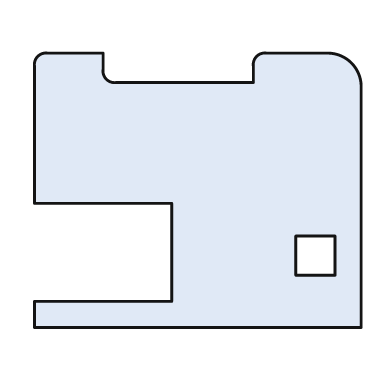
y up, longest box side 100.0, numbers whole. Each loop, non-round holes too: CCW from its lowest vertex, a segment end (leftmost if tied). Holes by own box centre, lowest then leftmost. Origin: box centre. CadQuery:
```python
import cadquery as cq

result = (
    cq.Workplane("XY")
    .moveTo(-50.0, -42.0)
    .lineTo(50.0, -42.0)
    .lineTo(50.0, 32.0)
    .threePointArc((47.0, 39.0), (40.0, 42.0))
    .lineTo(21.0, 42.0)
    .threePointArc((18.0, 41.0), (17.0, 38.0))
    .lineTo(17.0, 33.0)
    .lineTo(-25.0, 33.0)
    .threePointArc((-28.0, 34.0), (-29.0, 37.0))
    .lineTo(-29.0, 42.0)
    .lineTo(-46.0, 42.0)
    .threePointArc((-49.0, 41.0), (-50.0, 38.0))
    .lineTo(-50.0, -4.0)
    .lineTo(-8.0, -4.0)
    .lineTo(-8.0, -34.0)
    .lineTo(-50.0, -34.0)
    .close()
    .moveTo(30.0, -26.0)
    .lineTo(42.0, -26.0)
    .lineTo(42.0, -14.0)
    .lineTo(30.0, -14.0)
    .close()
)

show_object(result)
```